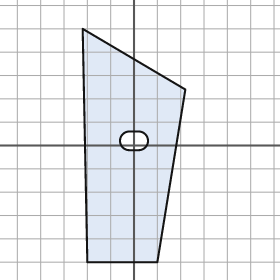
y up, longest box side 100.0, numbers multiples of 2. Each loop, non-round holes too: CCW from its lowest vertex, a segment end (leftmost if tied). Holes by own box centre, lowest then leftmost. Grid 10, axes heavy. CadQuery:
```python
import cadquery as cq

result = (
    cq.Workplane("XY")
    .moveTo(-20.0, -50.0)
    .lineTo(10.0, -50.0)
    .lineTo(22.0, 24.0)
    .lineTo(-22.0, 50.0)
    .close()
    .moveTo(-2.0, -2.0)
    .lineTo(2.0, -2.0)
    .threePointArc((6.0, 2.0), (2.0, 6.0))
    .lineTo(-2.0, 6.0)
    .threePointArc((-6.0, 2.0), (-2.0, -2.0))
    .close()
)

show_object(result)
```